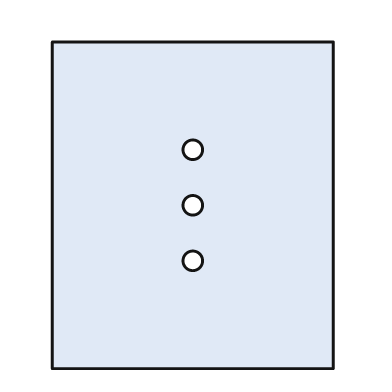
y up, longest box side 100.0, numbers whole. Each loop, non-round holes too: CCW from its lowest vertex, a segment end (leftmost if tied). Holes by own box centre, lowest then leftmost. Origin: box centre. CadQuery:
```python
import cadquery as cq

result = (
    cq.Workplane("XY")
    .moveTo(-43.0, -50.0)
    .lineTo(43.0, -50.0)
    .lineTo(43.0, 50.0)
    .lineTo(-43.0, 50.0)
    .close()
    .moveTo(0.0, -17.0)
    .circle(3.0)
    .moveTo(0.0, 0.0)
    .circle(3.0)
    .moveTo(0.0, 17.0)
    .circle(3.0)
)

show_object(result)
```